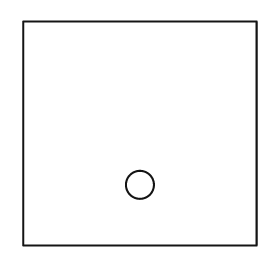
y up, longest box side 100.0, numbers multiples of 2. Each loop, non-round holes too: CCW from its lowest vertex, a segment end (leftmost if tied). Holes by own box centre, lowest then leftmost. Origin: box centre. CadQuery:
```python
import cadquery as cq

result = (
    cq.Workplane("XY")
    .moveTo(-50.0, -48.0)
    .lineTo(50.0, -48.0)
    .lineTo(50.0, 48.0)
    .lineTo(-50.0, 48.0)
    .close()
    .moveTo(0.0, -22.0)
    .circle(6.0)
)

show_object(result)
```